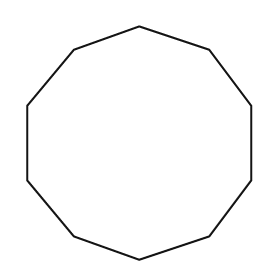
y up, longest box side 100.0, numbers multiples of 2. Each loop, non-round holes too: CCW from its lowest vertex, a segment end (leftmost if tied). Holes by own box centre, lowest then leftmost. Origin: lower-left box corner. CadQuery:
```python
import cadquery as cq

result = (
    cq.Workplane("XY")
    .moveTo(48.0, 0.0)
    .lineTo(78.0, 10.0)
    .lineTo(96.0, 34.0)
    .lineTo(96.0, 66.0)
    .lineTo(78.0, 90.0)
    .lineTo(48.0, 100.0)
    .lineTo(20.0, 90.0)
    .lineTo(0.0, 66.0)
    .lineTo(0.0, 34.0)
    .lineTo(20.0, 10.0)
    .close()
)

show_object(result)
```